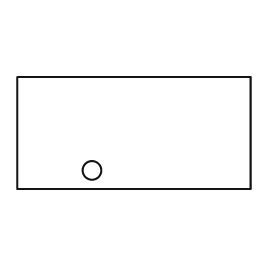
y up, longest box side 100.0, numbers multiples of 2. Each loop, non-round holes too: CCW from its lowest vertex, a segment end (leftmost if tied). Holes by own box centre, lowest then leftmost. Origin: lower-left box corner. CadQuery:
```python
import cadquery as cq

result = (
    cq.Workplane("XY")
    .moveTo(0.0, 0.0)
    .lineTo(100.0, 0.0)
    .lineTo(100.0, 48.0)
    .lineTo(0.0, 48.0)
    .close()
    .moveTo(32.0, 8.0)
    .circle(4.0)
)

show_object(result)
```